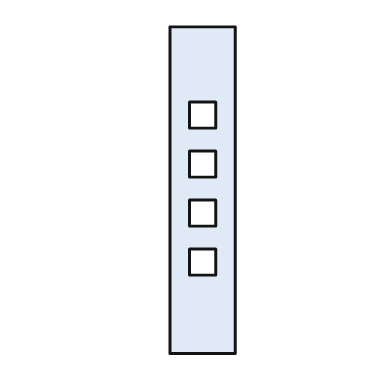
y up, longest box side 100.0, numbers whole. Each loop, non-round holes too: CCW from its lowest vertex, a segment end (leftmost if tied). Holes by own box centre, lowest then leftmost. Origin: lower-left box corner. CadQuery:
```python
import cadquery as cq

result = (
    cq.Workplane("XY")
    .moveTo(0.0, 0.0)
    .lineTo(20.0, 0.0)
    .lineTo(20.0, 100.0)
    .lineTo(0.0, 100.0)
    .close()
    .moveTo(6.0, 24.0)
    .lineTo(14.0, 24.0)
    .lineTo(14.0, 32.0)
    .lineTo(6.0, 32.0)
    .close()
    .moveTo(6.0, 39.0)
    .lineTo(14.0, 39.0)
    .lineTo(14.0, 47.0)
    .lineTo(6.0, 47.0)
    .close()
    .moveTo(6.0, 54.0)
    .lineTo(14.0, 54.0)
    .lineTo(14.0, 62.0)
    .lineTo(6.0, 62.0)
    .close()
    .moveTo(6.0, 69.0)
    .lineTo(14.0, 69.0)
    .lineTo(14.0, 77.0)
    .lineTo(6.0, 77.0)
    .close()
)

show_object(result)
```